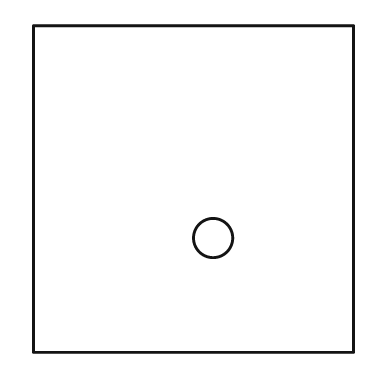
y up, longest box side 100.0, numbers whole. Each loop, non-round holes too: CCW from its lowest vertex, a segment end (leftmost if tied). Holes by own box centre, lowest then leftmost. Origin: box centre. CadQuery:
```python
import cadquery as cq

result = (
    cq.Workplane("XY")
    .moveTo(-49.0, -50.0)
    .lineTo(49.0, -50.0)
    .lineTo(49.0, 50.0)
    .lineTo(-49.0, 50.0)
    .close()
    .moveTo(6.0, -15.0)
    .circle(6.0)
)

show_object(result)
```